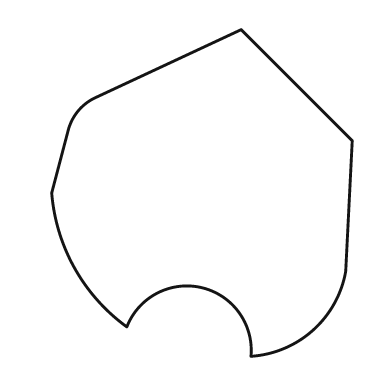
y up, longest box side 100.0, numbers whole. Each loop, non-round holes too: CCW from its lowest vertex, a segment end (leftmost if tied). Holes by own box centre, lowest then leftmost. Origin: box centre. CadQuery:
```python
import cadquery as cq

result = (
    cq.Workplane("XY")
    .moveTo(15.0, -50.0)
    .threePointArc((34.0, -42.0), (44.0, -24.0))
    .lineTo(46.0, 16.0)
    .lineTo(12.0, 50.0)
    .lineTo(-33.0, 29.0)
    .threePointArc((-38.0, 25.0), (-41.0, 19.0))
    .lineTo(-46.0, 0.0)
    .threePointArc((-39.0, -23.0), (-23.0, -41.0))
    .threePointArc((0.0, -29.0), (15.0, -50.0))
    .close()
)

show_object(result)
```